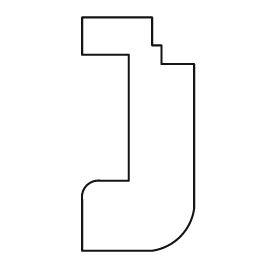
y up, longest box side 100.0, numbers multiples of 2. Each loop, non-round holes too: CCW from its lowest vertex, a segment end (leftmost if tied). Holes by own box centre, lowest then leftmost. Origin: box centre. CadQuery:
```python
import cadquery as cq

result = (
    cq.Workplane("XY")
    .moveTo(-24.0, -50.0)
    .lineTo(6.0, -50.0)
    .threePointArc((18.0, -44.0), (24.0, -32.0))
    .lineTo(24.0, 30.0)
    .lineTo(10.0, 30.0)
    .lineTo(10.0, 38.0)
    .lineTo(6.0, 38.0)
    .lineTo(6.0, 50.0)
    .lineTo(-24.0, 50.0)
    .lineTo(-24.0, 34.0)
    .lineTo(-4.0, 34.0)
    .lineTo(-4.0, -20.0)
    .lineTo(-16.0, -20.0)
    .threePointArc((-22.0, -22.0), (-24.0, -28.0))
    .close()
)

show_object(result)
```